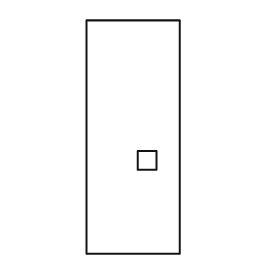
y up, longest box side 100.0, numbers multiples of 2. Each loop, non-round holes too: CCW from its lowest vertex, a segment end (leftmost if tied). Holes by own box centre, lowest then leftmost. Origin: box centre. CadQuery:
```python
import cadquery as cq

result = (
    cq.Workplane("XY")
    .moveTo(-20.0, -50.0)
    .lineTo(20.0, -50.0)
    .lineTo(20.0, 50.0)
    .lineTo(-20.0, 50.0)
    .close()
    .moveTo(2.0, -14.0)
    .lineTo(10.0, -14.0)
    .lineTo(10.0, -6.0)
    .lineTo(2.0, -6.0)
    .close()
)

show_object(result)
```